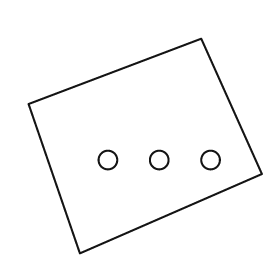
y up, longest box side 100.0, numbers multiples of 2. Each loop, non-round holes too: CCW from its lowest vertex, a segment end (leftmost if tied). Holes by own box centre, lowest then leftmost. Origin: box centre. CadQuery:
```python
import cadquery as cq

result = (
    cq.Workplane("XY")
    .moveTo(-28.0, -46.0)
    .lineTo(50.0, -12.0)
    .lineTo(24.0, 46.0)
    .lineTo(-50.0, 18.0)
    .close()
    .moveTo(-16.0, -6.0)
    .circle(4.0)
    .moveTo(6.0, -6.0)
    .circle(4.0)
    .moveTo(28.0, -6.0)
    .circle(4.0)
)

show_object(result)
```